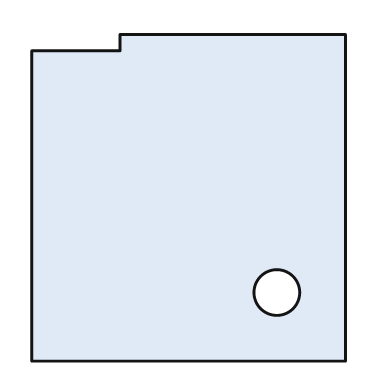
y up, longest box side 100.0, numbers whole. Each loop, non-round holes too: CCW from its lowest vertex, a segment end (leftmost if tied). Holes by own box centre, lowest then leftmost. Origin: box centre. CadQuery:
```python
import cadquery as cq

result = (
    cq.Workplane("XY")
    .moveTo(-48.0, -50.0)
    .lineTo(48.0, -50.0)
    .lineTo(48.0, 50.0)
    .lineTo(-21.0, 50.0)
    .lineTo(-21.0, 45.0)
    .lineTo(-48.0, 45.0)
    .close()
    .moveTo(27.0, -29.0)
    .circle(7.0)
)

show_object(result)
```